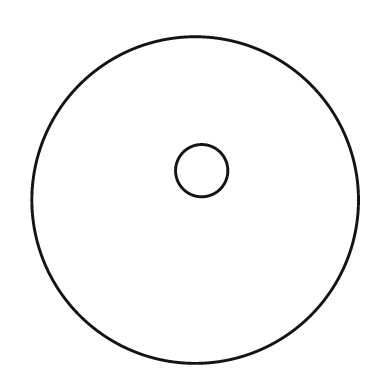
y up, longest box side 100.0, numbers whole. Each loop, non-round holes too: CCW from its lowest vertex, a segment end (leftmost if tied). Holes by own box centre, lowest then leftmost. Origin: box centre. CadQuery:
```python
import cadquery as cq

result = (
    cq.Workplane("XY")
    .moveTo(0.0, 0.0)
    .circle(50.0)
    .moveTo(2.0, 9.0)
    .circle(8.0)
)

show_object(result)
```